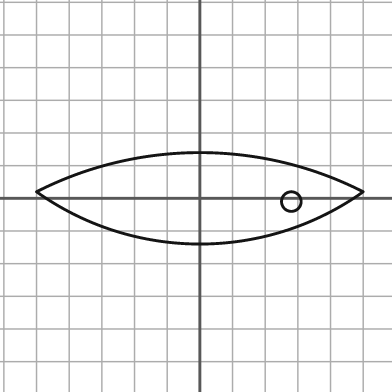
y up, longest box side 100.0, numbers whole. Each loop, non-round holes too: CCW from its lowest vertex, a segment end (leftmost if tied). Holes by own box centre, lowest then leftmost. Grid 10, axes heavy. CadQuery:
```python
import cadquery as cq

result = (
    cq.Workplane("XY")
    .moveTo(-50.0, 2.0)
    .threePointArc((0.0, -14.0), (50.0, 2.0))
    .threePointArc((0.0, 14.0), (-50.0, 2.0))
    .close()
    .moveTo(28.0, -1.0)
    .circle(3.0)
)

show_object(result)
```